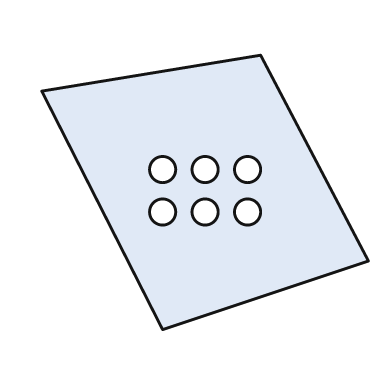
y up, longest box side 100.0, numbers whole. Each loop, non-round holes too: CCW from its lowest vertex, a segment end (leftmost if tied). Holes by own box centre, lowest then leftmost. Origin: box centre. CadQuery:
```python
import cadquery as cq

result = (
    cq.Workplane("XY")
    .moveTo(-13.0, -42.0)
    .lineTo(50.0, -21.0)
    .lineTo(17.0, 42.0)
    .lineTo(-50.0, 31.0)
    .close()
    .moveTo(-13.0, -6.0)
    .circle(4.0)
    .moveTo(0.0, -6.0)
    .circle(4.0)
    .moveTo(13.0, -6.0)
    .circle(4.0)
    .moveTo(-13.0, 7.0)
    .circle(4.0)
    .moveTo(0.0, 7.0)
    .circle(4.0)
    .moveTo(13.0, 7.0)
    .circle(4.0)
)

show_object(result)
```